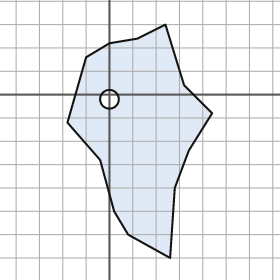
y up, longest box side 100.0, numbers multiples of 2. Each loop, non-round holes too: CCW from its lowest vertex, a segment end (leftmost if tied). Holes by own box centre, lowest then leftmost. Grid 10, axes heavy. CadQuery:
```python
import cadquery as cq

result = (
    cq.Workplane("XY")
    .moveTo(26.0, -70.0)
    .lineTo(28.0, -40.0)
    .lineTo(34.0, -24.0)
    .lineTo(44.0, -8.0)
    .lineTo(32.0, 4.0)
    .lineTo(24.0, 30.0)
    .lineTo(12.0, 24.0)
    .lineTo(0.0, 22.0)
    .lineTo(-10.0, 16.0)
    .lineTo(-18.0, -12.0)
    .lineTo(-4.0, -28.0)
    .lineTo(2.0, -50.0)
    .lineTo(8.0, -60.0)
    .close()
    .moveTo(0.0, -2.0)
    .circle(4.0)
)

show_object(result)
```